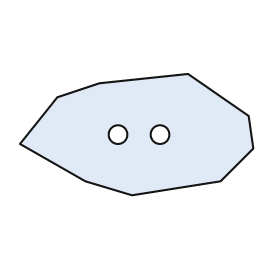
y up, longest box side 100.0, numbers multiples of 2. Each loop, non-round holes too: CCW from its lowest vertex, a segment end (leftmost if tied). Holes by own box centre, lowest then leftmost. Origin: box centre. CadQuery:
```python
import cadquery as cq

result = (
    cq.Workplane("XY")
    .moveTo(-2.0, -26.0)
    .lineTo(36.0, -20.0)
    .lineTo(50.0, -6.0)
    .lineTo(48.0, 8.0)
    .lineTo(22.0, 26.0)
    .lineTo(-16.0, 22.0)
    .lineTo(-34.0, 16.0)
    .lineTo(-50.0, -4.0)
    .lineTo(-22.0, -20.0)
    .close()
    .moveTo(-8.0, 0.0)
    .circle(4.0)
    .moveTo(10.0, 0.0)
    .circle(4.0)
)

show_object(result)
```